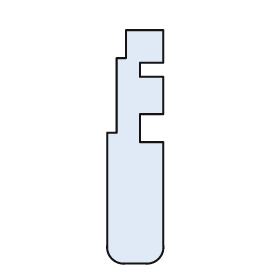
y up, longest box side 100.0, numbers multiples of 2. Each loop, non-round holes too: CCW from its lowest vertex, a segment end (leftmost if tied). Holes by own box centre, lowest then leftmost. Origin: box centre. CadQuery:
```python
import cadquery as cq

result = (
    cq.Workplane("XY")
    .moveTo(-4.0, -50.0)
    .lineTo(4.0, -50.0)
    .threePointArc((10.0, -48.0), (12.0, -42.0))
    .lineTo(12.0, 2.0)
    .lineTo(2.0, 2.0)
    .lineTo(2.0, 14.0)
    .lineTo(12.0, 14.0)
    .lineTo(12.0, 30.0)
    .lineTo(2.0, 30.0)
    .lineTo(2.0, 36.0)
    .lineTo(12.0, 36.0)
    .lineTo(12.0, 50.0)
    .lineTo(-4.0, 50.0)
    .lineTo(-4.0, 38.0)
    .lineTo(-8.0, 38.0)
    .lineTo(-8.0, 6.0)
    .lineTo(-12.0, 6.0)
    .lineTo(-12.0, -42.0)
    .threePointArc((-10.0, -48.0), (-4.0, -50.0))
    .close()
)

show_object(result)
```